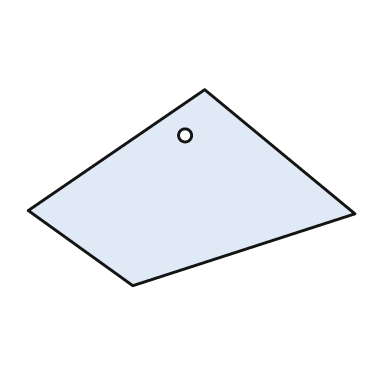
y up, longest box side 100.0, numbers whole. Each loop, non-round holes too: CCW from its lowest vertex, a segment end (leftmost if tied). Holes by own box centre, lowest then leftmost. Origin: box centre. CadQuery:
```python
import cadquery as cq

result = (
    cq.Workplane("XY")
    .moveTo(-18.0, -30.0)
    .lineTo(50.0, -8.0)
    .lineTo(4.0, 30.0)
    .lineTo(-50.0, -7.0)
    .close()
    .moveTo(-2.0, 16.0)
    .circle(2.0)
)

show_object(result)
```